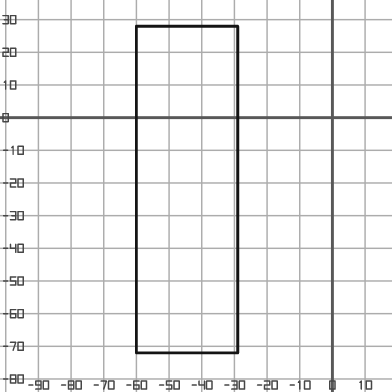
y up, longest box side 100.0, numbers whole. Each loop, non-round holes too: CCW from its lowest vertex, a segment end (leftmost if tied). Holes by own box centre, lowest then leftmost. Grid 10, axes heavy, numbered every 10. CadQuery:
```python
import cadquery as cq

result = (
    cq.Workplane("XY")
    .moveTo(-60.0, -72.0)
    .lineTo(-29.0, -72.0)
    .lineTo(-29.0, 28.0)
    .lineTo(-60.0, 28.0)
    .close()
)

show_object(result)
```